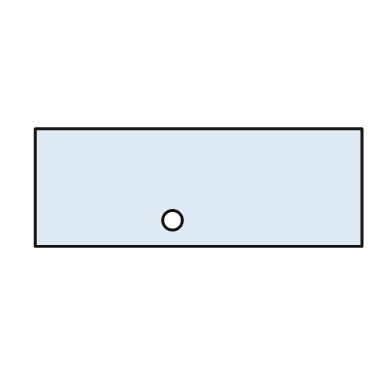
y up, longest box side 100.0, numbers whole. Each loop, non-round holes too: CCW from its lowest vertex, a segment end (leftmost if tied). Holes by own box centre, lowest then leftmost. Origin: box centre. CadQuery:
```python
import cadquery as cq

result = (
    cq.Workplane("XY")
    .moveTo(-50.0, -18.0)
    .lineTo(50.0, -18.0)
    .lineTo(50.0, 18.0)
    .lineTo(-50.0, 18.0)
    .close()
    .moveTo(-8.0, -10.0)
    .circle(3.0)
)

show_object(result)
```